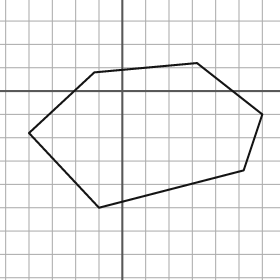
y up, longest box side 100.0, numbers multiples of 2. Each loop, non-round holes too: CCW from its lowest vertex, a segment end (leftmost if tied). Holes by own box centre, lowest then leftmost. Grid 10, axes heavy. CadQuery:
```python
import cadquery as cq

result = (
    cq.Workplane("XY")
    .moveTo(-10.0, -50.0)
    .lineTo(52.0, -34.0)
    .lineTo(60.0, -10.0)
    .lineTo(32.0, 12.0)
    .lineTo(-12.0, 8.0)
    .lineTo(-40.0, -18.0)
    .close()
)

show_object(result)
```